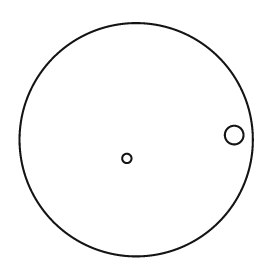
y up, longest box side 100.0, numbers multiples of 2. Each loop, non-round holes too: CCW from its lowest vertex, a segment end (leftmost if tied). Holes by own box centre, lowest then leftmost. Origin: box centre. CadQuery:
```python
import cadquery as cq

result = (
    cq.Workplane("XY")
    .moveTo(0.0, 0.0)
    .circle(50.0)
    .moveTo(-4.0, -8.0)
    .circle(2.0)
    .moveTo(42.0, 2.0)
    .circle(4.0)
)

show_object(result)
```